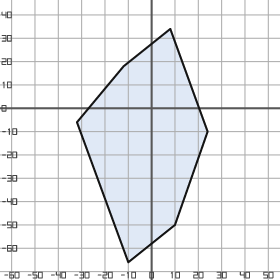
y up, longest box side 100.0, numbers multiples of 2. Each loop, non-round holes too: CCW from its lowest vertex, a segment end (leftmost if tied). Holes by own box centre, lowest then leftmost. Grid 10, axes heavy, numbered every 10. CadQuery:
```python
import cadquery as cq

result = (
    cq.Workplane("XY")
    .moveTo(-10.0, -66.0)
    .lineTo(10.0, -50.0)
    .lineTo(24.0, -10.0)
    .lineTo(8.0, 34.0)
    .lineTo(-12.0, 18.0)
    .lineTo(-32.0, -6.0)
    .close()
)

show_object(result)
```